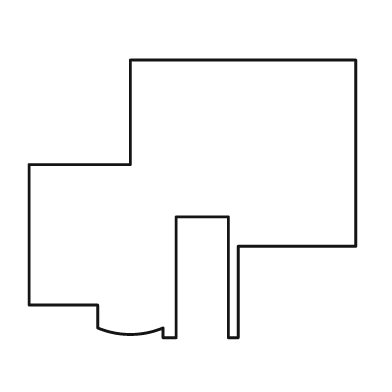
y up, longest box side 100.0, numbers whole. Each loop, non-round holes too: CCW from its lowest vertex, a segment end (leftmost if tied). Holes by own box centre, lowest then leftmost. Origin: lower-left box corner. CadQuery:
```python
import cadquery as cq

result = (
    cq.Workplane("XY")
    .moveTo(41.0, 0.0)
    .lineTo(45.0, 0.0)
    .lineTo(45.0, 37.0)
    .lineTo(61.0, 37.0)
    .lineTo(61.0, 0.0)
    .lineTo(64.0, 0.0)
    .lineTo(64.0, 28.0)
    .lineTo(100.0, 28.0)
    .lineTo(100.0, 85.0)
    .lineTo(31.0, 85.0)
    .lineTo(31.0, 53.0)
    .lineTo(0.0, 53.0)
    .lineTo(0.0, 10.0)
    .lineTo(21.0, 10.0)
    .lineTo(21.0, 3.0)
    .threePointArc((31.0, 1.0), (41.0, 3.0))
    .close()
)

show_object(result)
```